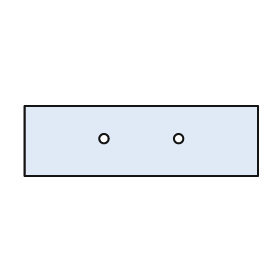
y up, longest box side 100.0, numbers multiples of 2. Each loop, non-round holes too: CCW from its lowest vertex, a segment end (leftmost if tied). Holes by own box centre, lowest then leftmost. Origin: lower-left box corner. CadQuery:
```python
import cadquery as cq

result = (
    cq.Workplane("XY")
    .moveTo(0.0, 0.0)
    .lineTo(100.0, 0.0)
    .lineTo(100.0, 30.0)
    .lineTo(0.0, 30.0)
    .close()
    .moveTo(34.0, 16.0)
    .circle(2.0)
    .moveTo(66.0, 16.0)
    .circle(2.0)
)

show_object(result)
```